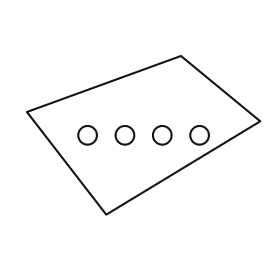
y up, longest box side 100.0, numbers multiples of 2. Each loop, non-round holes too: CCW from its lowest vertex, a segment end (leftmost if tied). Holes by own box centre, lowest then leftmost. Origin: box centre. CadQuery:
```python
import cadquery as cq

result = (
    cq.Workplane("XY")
    .moveTo(-16.0, -34.0)
    .lineTo(50.0, 6.0)
    .lineTo(16.0, 34.0)
    .lineTo(-50.0, 10.0)
    .close()
    .moveTo(-24.0, 0.0)
    .circle(4.0)
    .moveTo(-8.0, 0.0)
    .circle(4.0)
    .moveTo(8.0, 0.0)
    .circle(4.0)
    .moveTo(24.0, 0.0)
    .circle(4.0)
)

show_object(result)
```